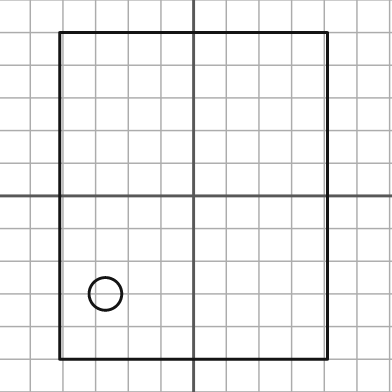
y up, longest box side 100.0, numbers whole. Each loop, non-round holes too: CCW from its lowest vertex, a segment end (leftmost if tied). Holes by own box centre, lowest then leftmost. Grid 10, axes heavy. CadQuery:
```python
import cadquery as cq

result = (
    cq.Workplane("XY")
    .moveTo(-41.0, -50.0)
    .lineTo(41.0, -50.0)
    .lineTo(41.0, 50.0)
    .lineTo(-41.0, 50.0)
    .close()
    .moveTo(-27.0, -30.0)
    .circle(5.0)
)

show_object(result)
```